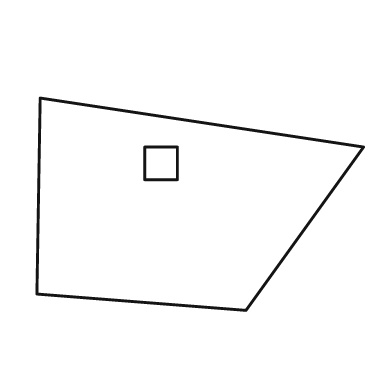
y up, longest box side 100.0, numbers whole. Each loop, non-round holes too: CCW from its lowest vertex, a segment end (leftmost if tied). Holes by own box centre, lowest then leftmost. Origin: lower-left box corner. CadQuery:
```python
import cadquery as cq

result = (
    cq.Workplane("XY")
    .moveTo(64.0, 0.0)
    .lineTo(100.0, 50.0)
    .lineTo(1.0, 65.0)
    .lineTo(0.0, 5.0)
    .close()
    .moveTo(33.0, 40.0)
    .lineTo(43.0, 40.0)
    .lineTo(43.0, 50.0)
    .lineTo(33.0, 50.0)
    .close()
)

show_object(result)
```